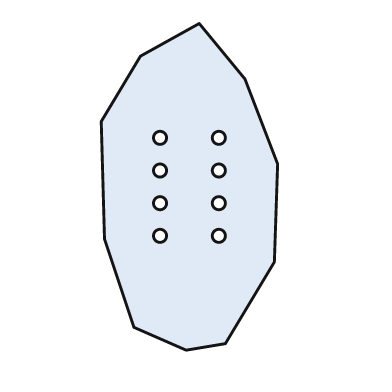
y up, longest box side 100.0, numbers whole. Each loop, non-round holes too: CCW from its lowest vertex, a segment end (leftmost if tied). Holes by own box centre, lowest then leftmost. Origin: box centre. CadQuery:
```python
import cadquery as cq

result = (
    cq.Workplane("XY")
    .moveTo(-1.0, -50.0)
    .lineTo(11.0, -48.0)
    .lineTo(26.0, -23.0)
    .lineTo(27.0, 7.0)
    .lineTo(17.0, 33.0)
    .lineTo(3.0, 50.0)
    .lineTo(-15.0, 40.0)
    .lineTo(-27.0, 20.0)
    .lineTo(-26.0, -16.0)
    .lineTo(-17.0, -43.0)
    .close()
    .moveTo(-9.0, -15.0)
    .circle(2.0)
    .moveTo(9.0, -15.0)
    .circle(2.0)
    .moveTo(-9.0, -5.0)
    .circle(2.0)
    .moveTo(9.0, -5.0)
    .circle(2.0)
    .moveTo(-9.0, 5.0)
    .circle(2.0)
    .moveTo(9.0, 5.0)
    .circle(2.0)
    .moveTo(-9.0, 15.0)
    .circle(2.0)
    .moveTo(9.0, 15.0)
    .circle(2.0)
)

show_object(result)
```